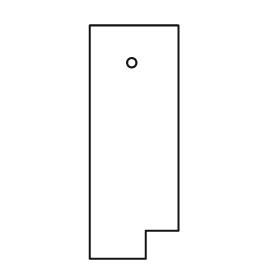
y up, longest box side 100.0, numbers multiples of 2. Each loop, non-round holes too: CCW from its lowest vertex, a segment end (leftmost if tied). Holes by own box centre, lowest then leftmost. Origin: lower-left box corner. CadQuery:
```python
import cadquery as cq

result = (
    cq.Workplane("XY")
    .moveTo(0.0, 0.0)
    .lineTo(24.0, 0.0)
    .lineTo(24.0, 12.0)
    .lineTo(38.0, 12.0)
    .lineTo(38.0, 100.0)
    .lineTo(0.0, 100.0)
    .close()
    .moveTo(18.0, 84.0)
    .circle(2.0)
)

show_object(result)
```